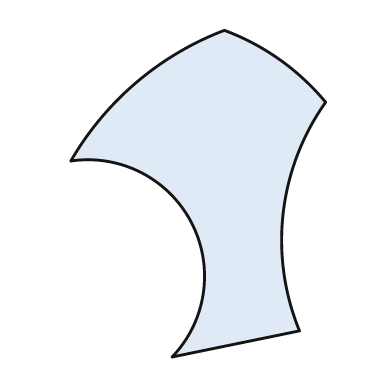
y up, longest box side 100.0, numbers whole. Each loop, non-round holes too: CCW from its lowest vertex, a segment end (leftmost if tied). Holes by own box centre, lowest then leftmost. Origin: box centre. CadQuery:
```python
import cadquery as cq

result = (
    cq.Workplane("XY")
    .moveTo(-8.0, -50.0)
    .lineTo(31.0, -42.0)
    .threePointArc((26.0, -6.0), (39.0, 28.0))
    .threePointArc((25.0, 41.0), (8.0, 50.0))
    .threePointArc((-19.0, 34.0), (-39.0, 10.0))
    .threePointArc((-2.0, -9.0), (-8.0, -50.0))
    .close()
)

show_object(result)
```